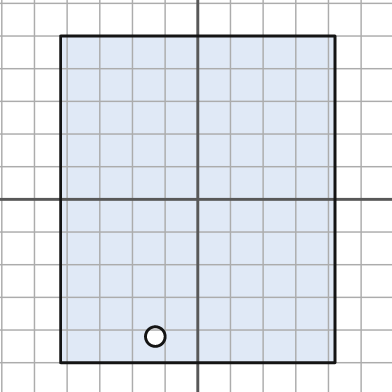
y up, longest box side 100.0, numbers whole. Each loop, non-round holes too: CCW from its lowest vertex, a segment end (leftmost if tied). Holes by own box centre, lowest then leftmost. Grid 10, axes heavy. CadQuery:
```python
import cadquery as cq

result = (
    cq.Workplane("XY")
    .moveTo(-42.0, -50.0)
    .lineTo(42.0, -50.0)
    .lineTo(42.0, 50.0)
    .lineTo(-42.0, 50.0)
    .close()
    .moveTo(-13.0, -42.0)
    .circle(3.0)
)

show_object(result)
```